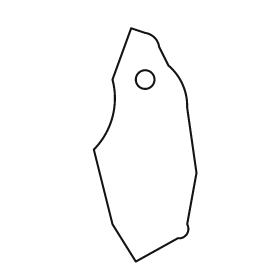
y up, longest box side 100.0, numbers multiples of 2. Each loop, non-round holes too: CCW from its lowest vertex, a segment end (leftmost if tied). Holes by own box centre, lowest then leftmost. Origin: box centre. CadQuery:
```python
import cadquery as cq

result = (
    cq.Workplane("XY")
    .moveTo(-4.0, -50.0)
    .lineTo(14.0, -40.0)
    .threePointArc((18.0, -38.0), (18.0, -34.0))
    .lineTo(22.0, -12.0)
    .lineTo(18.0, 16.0)
    .threePointArc((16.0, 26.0), (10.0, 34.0))
    .lineTo(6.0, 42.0)
    .threePointArc((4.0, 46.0), (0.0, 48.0))
    .lineTo(-6.0, 50.0)
    .lineTo(-14.0, 28.0)
    .threePointArc((-14.0, 12.0), (-22.0, -2.0))
    .lineTo(-14.0, -34.0)
    .close()
    .moveTo(0.0, 28.0)
    .circle(4.0)
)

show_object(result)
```